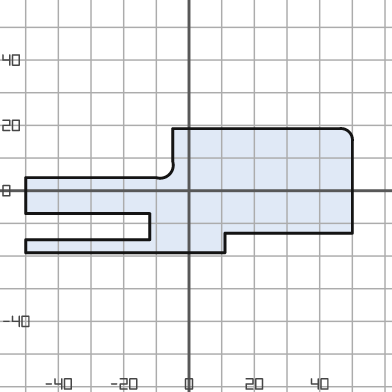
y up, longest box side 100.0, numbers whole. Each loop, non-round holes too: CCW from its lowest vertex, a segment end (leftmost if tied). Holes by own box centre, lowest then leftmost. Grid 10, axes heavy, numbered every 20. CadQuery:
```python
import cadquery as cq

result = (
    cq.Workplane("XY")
    .moveTo(-50.0, -19.0)
    .lineTo(11.0, -19.0)
    .lineTo(11.0, -13.0)
    .lineTo(50.0, -13.0)
    .lineTo(50.0, 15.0)
    .threePointArc((49.0, 18.0), (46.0, 19.0))
    .lineTo(-5.0, 19.0)
    .lineTo(-5.0, 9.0)
    .threePointArc((-6.0, 5.0), (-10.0, 4.0))
    .lineTo(-50.0, 4.0)
    .lineTo(-50.0, -7.0)
    .lineTo(-12.0, -7.0)
    .lineTo(-12.0, -15.0)
    .lineTo(-50.0, -15.0)
    .close()
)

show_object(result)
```